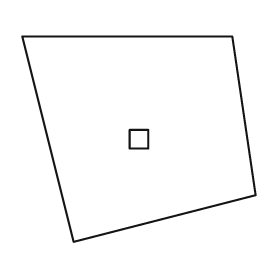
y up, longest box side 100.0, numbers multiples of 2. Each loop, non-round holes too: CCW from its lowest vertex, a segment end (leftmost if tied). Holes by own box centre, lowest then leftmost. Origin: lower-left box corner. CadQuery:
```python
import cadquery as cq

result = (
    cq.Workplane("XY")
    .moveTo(22.0, 0.0)
    .lineTo(100.0, 20.0)
    .lineTo(90.0, 88.0)
    .lineTo(0.0, 88.0)
    .close()
    .moveTo(46.0, 40.0)
    .lineTo(54.0, 40.0)
    .lineTo(54.0, 48.0)
    .lineTo(46.0, 48.0)
    .close()
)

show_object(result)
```